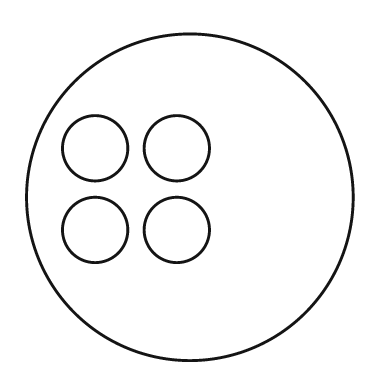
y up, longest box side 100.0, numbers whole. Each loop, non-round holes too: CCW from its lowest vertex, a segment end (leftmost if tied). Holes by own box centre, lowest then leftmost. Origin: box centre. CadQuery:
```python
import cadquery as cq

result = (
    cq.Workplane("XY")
    .moveTo(0.0, 0.0)
    .circle(50.0)
    .moveTo(-29.0, -10.0)
    .circle(10.0)
    .moveTo(-4.0, -10.0)
    .circle(10.0)
    .moveTo(-29.0, 15.0)
    .circle(10.0)
    .moveTo(-4.0, 15.0)
    .circle(10.0)
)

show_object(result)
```